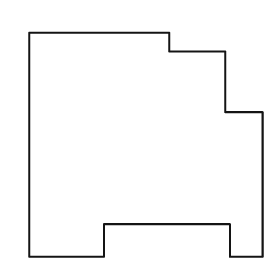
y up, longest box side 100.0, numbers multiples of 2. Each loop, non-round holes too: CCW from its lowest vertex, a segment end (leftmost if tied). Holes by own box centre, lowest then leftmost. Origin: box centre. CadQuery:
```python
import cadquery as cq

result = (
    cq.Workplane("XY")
    .moveTo(-50.0, -48.0)
    .lineTo(-18.0, -48.0)
    .lineTo(-18.0, -34.0)
    .lineTo(36.0, -34.0)
    .lineTo(36.0, -48.0)
    .lineTo(50.0, -48.0)
    .lineTo(50.0, 14.0)
    .lineTo(34.0, 14.0)
    .lineTo(34.0, 40.0)
    .lineTo(10.0, 40.0)
    .lineTo(10.0, 48.0)
    .lineTo(-50.0, 48.0)
    .close()
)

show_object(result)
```